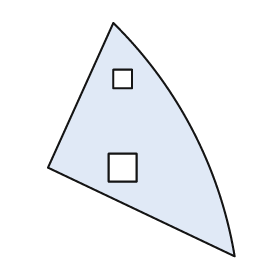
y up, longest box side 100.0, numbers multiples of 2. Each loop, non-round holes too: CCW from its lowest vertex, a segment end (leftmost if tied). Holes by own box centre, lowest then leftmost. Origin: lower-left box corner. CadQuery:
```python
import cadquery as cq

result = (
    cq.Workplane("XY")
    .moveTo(80.0, 0.0)
    .threePointArc((62.0, 54.0), (28.0, 100.0))
    .lineTo(0.0, 38.0)
    .close()
    .moveTo(26.0, 32.0)
    .lineTo(38.0, 32.0)
    .lineTo(38.0, 44.0)
    .lineTo(26.0, 44.0)
    .close()
    .moveTo(28.0, 72.0)
    .lineTo(36.0, 72.0)
    .lineTo(36.0, 80.0)
    .lineTo(28.0, 80.0)
    .close()
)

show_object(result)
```